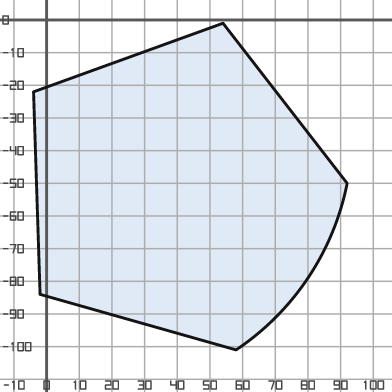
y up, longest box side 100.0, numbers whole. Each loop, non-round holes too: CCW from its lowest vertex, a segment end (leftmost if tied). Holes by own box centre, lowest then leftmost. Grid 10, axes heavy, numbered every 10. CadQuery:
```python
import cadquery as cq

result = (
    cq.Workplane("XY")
    .moveTo(58.0, -101.0)
    .threePointArc((80.0, -79.0), (92.0, -50.0))
    .lineTo(54.0, -1.0)
    .lineTo(-4.0, -22.0)
    .lineTo(-2.0, -84.0)
    .close()
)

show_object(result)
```